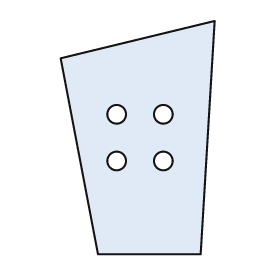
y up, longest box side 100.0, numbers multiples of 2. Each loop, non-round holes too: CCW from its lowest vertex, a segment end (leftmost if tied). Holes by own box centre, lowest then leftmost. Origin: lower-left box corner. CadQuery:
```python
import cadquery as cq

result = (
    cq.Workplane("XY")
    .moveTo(16.0, 0.0)
    .lineTo(60.0, 0.0)
    .lineTo(66.0, 100.0)
    .lineTo(0.0, 84.0)
    .close()
    .moveTo(24.0, 40.0)
    .circle(4.0)
    .moveTo(44.0, 40.0)
    .circle(4.0)
    .moveTo(24.0, 60.0)
    .circle(4.0)
    .moveTo(44.0, 60.0)
    .circle(4.0)
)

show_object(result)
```